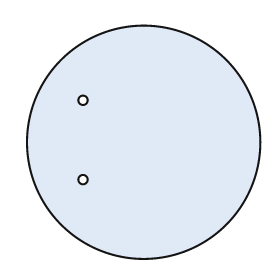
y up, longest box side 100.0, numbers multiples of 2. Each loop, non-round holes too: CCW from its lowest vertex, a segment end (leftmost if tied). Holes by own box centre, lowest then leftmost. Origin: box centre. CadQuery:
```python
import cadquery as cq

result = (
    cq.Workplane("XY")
    .moveTo(0.0, 0.0)
    .circle(50.0)
    .moveTo(-26.0, -16.0)
    .circle(2.0)
    .moveTo(-26.0, 18.0)
    .circle(2.0)
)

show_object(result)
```